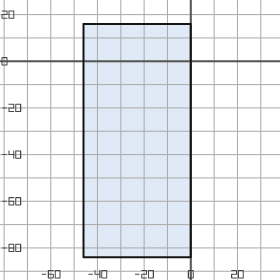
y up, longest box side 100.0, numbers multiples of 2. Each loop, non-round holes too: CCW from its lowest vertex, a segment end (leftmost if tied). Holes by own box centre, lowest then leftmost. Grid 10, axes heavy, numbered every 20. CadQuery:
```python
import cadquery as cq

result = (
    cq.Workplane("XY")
    .moveTo(-46.0, -84.0)
    .lineTo(0.0, -84.0)
    .lineTo(0.0, 16.0)
    .lineTo(-46.0, 16.0)
    .close()
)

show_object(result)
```